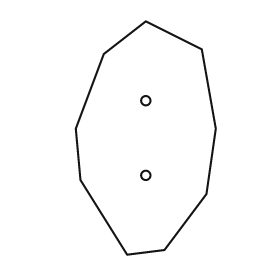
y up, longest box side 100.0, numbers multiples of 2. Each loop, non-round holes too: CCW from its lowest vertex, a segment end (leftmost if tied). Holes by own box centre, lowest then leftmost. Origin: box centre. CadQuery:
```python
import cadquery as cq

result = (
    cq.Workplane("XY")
    .moveTo(-8.0, -50.0)
    .lineTo(8.0, -48.0)
    .lineTo(26.0, -24.0)
    .lineTo(30.0, 4.0)
    .lineTo(24.0, 38.0)
    .lineTo(0.0, 50.0)
    .lineTo(-18.0, 36.0)
    .lineTo(-30.0, 4.0)
    .lineTo(-28.0, -18.0)
    .close()
    .moveTo(0.0, -16.0)
    .circle(2.0)
    .moveTo(0.0, 16.0)
    .circle(2.0)
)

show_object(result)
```